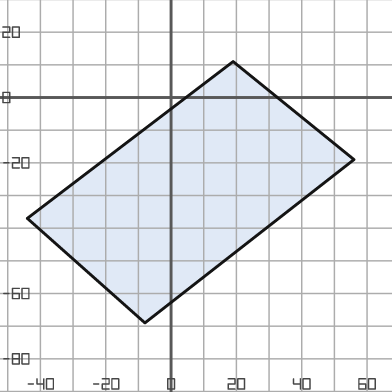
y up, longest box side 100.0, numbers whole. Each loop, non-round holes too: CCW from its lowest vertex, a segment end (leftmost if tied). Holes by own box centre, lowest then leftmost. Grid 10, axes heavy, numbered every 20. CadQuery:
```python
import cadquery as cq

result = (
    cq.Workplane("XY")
    .moveTo(-8.0, -69.0)
    .lineTo(56.0, -19.0)
    .lineTo(19.0, 11.0)
    .lineTo(-44.0, -37.0)
    .close()
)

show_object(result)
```